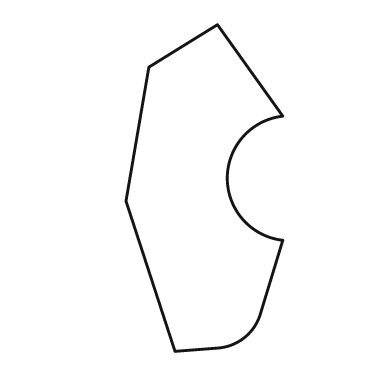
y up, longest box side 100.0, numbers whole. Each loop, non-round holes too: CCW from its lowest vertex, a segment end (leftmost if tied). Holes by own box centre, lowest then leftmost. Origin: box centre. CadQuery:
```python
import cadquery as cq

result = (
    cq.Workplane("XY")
    .moveTo(-9.0, -50.0)
    .lineTo(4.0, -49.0)
    .threePointArc((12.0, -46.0), (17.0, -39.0))
    .lineTo(24.0, -16.0)
    .threePointArc((7.0, 3.0), (24.0, 22.0))
    .lineTo(4.0, 50.0)
    .lineTo(-17.0, 37.0)
    .lineTo(-24.0, -4.0)
    .close()
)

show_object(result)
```